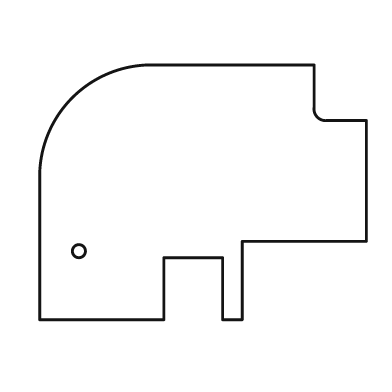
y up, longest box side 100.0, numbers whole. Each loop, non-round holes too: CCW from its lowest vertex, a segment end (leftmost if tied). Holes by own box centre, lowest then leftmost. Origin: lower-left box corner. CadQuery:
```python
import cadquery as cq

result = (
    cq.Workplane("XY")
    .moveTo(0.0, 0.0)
    .lineTo(38.0, 0.0)
    .lineTo(38.0, 19.0)
    .lineTo(56.0, 19.0)
    .lineTo(56.0, 0.0)
    .lineTo(62.0, 0.0)
    .lineTo(62.0, 24.0)
    .lineTo(100.0, 24.0)
    .lineTo(100.0, 61.0)
    .lineTo(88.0, 61.0)
    .threePointArc((85.0, 62.0), (84.0, 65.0))
    .lineTo(84.0, 78.0)
    .lineTo(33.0, 78.0)
    .threePointArc((10.0, 68.0), (0.0, 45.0))
    .close()
    .moveTo(12.0, 21.0)
    .circle(2.0)
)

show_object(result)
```